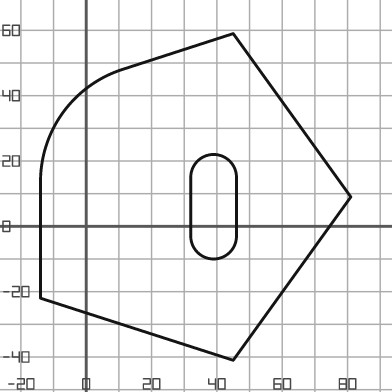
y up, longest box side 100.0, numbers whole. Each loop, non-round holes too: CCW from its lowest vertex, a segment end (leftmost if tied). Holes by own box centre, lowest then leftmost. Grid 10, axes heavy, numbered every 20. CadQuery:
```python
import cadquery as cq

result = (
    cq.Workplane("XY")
    .moveTo(45.0, -41.0)
    .lineTo(81.0, 9.0)
    .lineTo(45.0, 59.0)
    .lineTo(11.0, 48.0)
    .threePointArc((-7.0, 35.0), (-14.0, 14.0))
    .lineTo(-14.0, -22.0)
    .close()
    .moveTo(32.0, -3.0)
    .threePointArc((39.0, -10.0), (46.0, -3.0))
    .lineTo(46.0, 15.0)
    .threePointArc((39.0, 22.0), (32.0, 15.0))
    .close()
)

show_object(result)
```